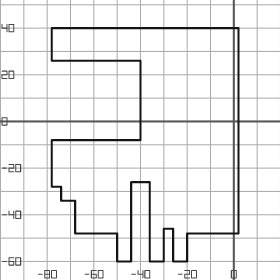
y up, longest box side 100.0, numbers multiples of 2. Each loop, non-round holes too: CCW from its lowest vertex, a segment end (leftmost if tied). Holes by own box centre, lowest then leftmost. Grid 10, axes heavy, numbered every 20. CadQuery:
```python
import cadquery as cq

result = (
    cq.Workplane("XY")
    .moveTo(-50.0, -60.0)
    .lineTo(-44.0, -60.0)
    .lineTo(-44.0, -26.0)
    .lineTo(-36.0, -26.0)
    .lineTo(-36.0, -60.0)
    .lineTo(-30.0, -60.0)
    .lineTo(-30.0, -46.0)
    .lineTo(-26.0, -46.0)
    .lineTo(-26.0, -60.0)
    .lineTo(-20.0, -60.0)
    .lineTo(-20.0, -48.0)
    .lineTo(2.0, -48.0)
    .lineTo(2.0, 40.0)
    .lineTo(-78.0, 40.0)
    .lineTo(-78.0, 26.0)
    .lineTo(-40.0, 26.0)
    .lineTo(-40.0, -8.0)
    .lineTo(-78.0, -8.0)
    .lineTo(-78.0, -28.0)
    .lineTo(-74.0, -28.0)
    .lineTo(-74.0, -34.0)
    .lineTo(-68.0, -34.0)
    .lineTo(-68.0, -48.0)
    .lineTo(-50.0, -48.0)
    .close()
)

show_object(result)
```